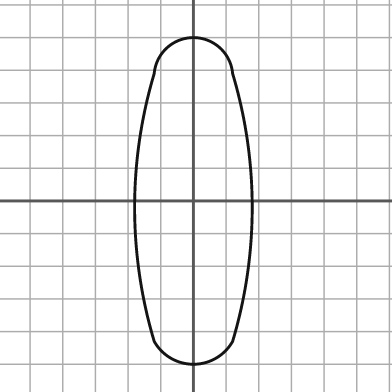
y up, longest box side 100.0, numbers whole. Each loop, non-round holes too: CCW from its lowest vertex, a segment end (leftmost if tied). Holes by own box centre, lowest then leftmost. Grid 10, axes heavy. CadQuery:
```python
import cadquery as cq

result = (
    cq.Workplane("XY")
    .moveTo(-12.0, -43.0)
    .threePointArc((0.0, -50.0), (12.0, -43.0))
    .threePointArc((18.0, -2.0), (12.0, 39.0))
    .threePointArc((0.0, 50.0), (-12.0, 39.0))
    .threePointArc((-18.0, -2.0), (-12.0, -43.0))
    .close()
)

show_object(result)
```